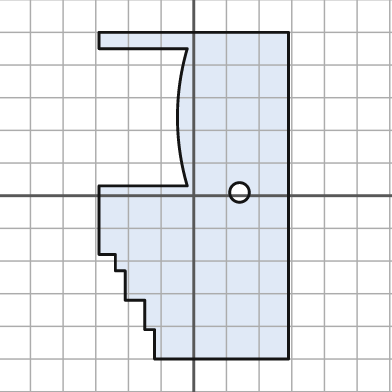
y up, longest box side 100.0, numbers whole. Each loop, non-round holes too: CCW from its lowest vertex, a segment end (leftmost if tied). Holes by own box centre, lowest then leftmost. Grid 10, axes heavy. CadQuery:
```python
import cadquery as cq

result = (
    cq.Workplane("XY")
    .moveTo(-12.0, -50.0)
    .lineTo(29.0, -50.0)
    .lineTo(29.0, 50.0)
    .lineTo(-29.0, 50.0)
    .lineTo(-29.0, 45.0)
    .lineTo(-2.0, 45.0)
    .threePointArc((-5.0, 24.0), (-2.0, 3.0))
    .lineTo(-29.0, 3.0)
    .lineTo(-29.0, -18.0)
    .lineTo(-24.0, -18.0)
    .lineTo(-24.0, -23.0)
    .lineTo(-21.0, -23.0)
    .lineTo(-21.0, -32.0)
    .lineTo(-15.0, -32.0)
    .lineTo(-15.0, -41.0)
    .lineTo(-12.0, -41.0)
    .close()
    .moveTo(14.0, 1.0)
    .circle(3.0)
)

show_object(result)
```